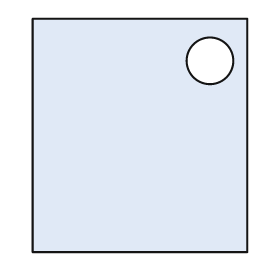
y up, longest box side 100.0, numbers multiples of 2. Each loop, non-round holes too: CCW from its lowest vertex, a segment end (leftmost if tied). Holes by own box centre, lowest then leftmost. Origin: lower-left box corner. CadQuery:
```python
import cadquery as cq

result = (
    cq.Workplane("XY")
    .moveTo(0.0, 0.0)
    .lineTo(92.0, 0.0)
    .lineTo(92.0, 100.0)
    .lineTo(0.0, 100.0)
    .close()
    .moveTo(76.0, 82.0)
    .circle(10.0)
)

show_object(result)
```